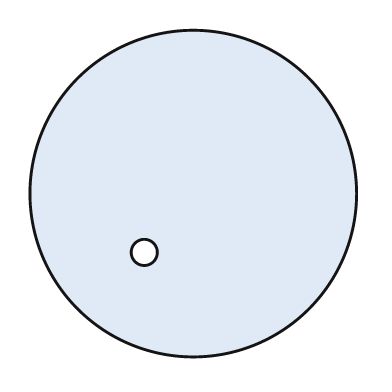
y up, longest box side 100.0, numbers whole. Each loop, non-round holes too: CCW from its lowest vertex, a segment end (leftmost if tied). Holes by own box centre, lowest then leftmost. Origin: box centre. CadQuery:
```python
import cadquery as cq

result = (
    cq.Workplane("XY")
    .moveTo(0.0, 0.0)
    .circle(50.0)
    .moveTo(-15.0, -18.0)
    .circle(4.0)
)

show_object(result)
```